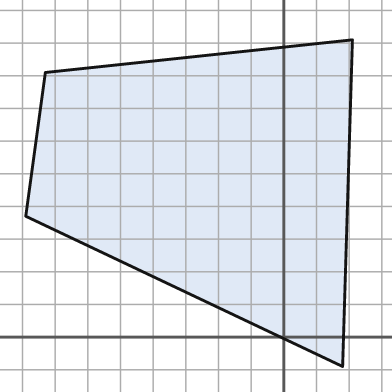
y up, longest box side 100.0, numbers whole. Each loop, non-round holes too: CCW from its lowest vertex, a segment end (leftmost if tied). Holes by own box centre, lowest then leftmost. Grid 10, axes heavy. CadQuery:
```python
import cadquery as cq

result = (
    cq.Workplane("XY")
    .moveTo(18.0, -9.0)
    .lineTo(21.0, 91.0)
    .lineTo(-73.0, 81.0)
    .lineTo(-79.0, 37.0)
    .close()
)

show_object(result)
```